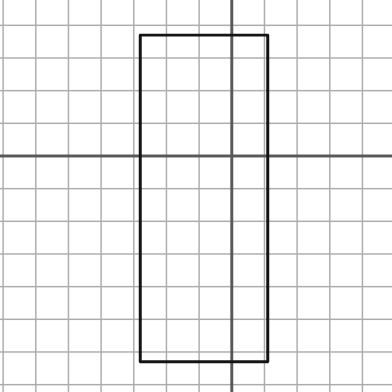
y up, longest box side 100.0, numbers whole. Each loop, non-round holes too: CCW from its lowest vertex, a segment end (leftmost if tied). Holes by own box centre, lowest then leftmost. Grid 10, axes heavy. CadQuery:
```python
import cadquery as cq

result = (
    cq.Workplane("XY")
    .moveTo(-28.0, -63.0)
    .lineTo(11.0, -63.0)
    .lineTo(11.0, 37.0)
    .lineTo(-28.0, 37.0)
    .close()
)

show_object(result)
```